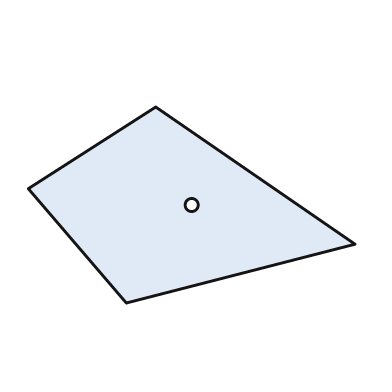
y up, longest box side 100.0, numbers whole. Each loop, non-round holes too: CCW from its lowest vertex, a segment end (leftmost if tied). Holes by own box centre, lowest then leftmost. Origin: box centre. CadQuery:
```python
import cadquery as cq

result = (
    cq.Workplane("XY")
    .moveTo(-20.0, -30.0)
    .lineTo(50.0, -12.0)
    .lineTo(-11.0, 30.0)
    .lineTo(-50.0, 5.0)
    .close()
    .moveTo(0.0, 0.0)
    .circle(2.0)
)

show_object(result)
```